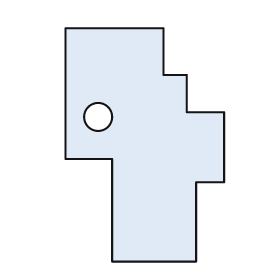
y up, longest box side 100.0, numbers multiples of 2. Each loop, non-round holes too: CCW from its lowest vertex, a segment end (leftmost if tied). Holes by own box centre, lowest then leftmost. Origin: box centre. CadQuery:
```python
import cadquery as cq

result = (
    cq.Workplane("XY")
    .moveTo(-14.0, -50.0)
    .lineTo(22.0, -50.0)
    .lineTo(22.0, -16.0)
    .lineTo(34.0, -16.0)
    .lineTo(34.0, 14.0)
    .lineTo(18.0, 14.0)
    .lineTo(18.0, 30.0)
    .lineTo(8.0, 30.0)
    .lineTo(8.0, 50.0)
    .lineTo(-34.0, 50.0)
    .lineTo(-34.0, -6.0)
    .lineTo(-14.0, -6.0)
    .close()
    .moveTo(-20.0, 12.0)
    .circle(6.0)
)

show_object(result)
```